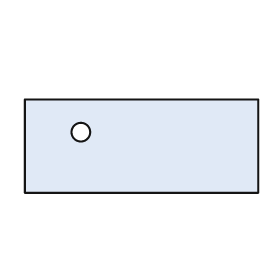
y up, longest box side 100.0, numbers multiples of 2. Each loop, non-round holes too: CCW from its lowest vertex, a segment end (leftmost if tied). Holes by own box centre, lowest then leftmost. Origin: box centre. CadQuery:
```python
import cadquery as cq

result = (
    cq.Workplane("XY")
    .moveTo(-50.0, -20.0)
    .lineTo(50.0, -20.0)
    .lineTo(50.0, 20.0)
    .lineTo(-50.0, 20.0)
    .close()
    .moveTo(-26.0, 6.0)
    .circle(4.0)
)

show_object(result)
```